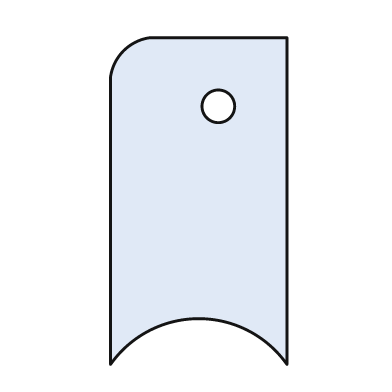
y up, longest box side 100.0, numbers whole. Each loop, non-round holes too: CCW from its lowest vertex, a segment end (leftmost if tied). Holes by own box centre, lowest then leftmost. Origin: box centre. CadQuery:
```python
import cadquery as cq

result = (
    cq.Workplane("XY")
    .moveTo(-27.0, -50.0)
    .threePointArc((0.0, -36.0), (27.0, -50.0))
    .lineTo(27.0, 50.0)
    .lineTo(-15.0, 50.0)
    .threePointArc((-23.0, 46.0), (-27.0, 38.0))
    .close()
    .moveTo(6.0, 29.0)
    .circle(5.0)
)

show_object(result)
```